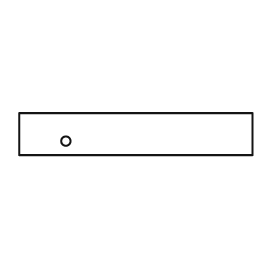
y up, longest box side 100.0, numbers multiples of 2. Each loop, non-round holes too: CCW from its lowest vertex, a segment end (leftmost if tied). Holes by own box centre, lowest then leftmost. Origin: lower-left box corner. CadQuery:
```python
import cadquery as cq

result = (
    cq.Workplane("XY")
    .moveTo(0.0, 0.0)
    .lineTo(100.0, 0.0)
    .lineTo(100.0, 18.0)
    .lineTo(0.0, 18.0)
    .close()
    .moveTo(20.0, 6.0)
    .circle(2.0)
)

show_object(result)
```